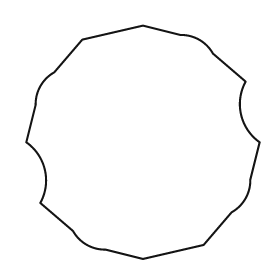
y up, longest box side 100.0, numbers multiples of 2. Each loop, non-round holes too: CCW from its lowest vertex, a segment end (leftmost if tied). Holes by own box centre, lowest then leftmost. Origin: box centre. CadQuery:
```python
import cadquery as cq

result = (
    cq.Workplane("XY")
    .moveTo(0.0, -50.0)
    .lineTo(26.0, -44.0)
    .lineTo(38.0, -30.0)
    .threePointArc((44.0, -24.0), (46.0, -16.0))
    .lineTo(50.0, 0.0)
    .threePointArc((42.0, 12.0), (44.0, 26.0))
    .lineTo(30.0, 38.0)
    .threePointArc((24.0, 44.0), (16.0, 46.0))
    .lineTo(0.0, 50.0)
    .lineTo(-26.0, 44.0)
    .lineTo(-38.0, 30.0)
    .threePointArc((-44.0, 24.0), (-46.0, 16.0))
    .lineTo(-50.0, 0.0)
    .threePointArc((-42.0, -12.0), (-44.0, -26.0))
    .lineTo(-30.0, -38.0)
    .threePointArc((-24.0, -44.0), (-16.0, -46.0))
    .close()
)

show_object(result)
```